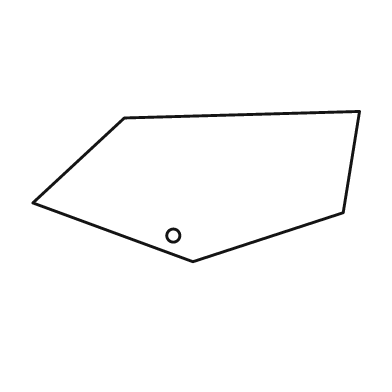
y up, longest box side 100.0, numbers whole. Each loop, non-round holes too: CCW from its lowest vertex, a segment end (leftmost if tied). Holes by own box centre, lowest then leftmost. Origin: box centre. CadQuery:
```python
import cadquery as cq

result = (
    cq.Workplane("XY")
    .moveTo(-1.0, -23.0)
    .lineTo(45.0, -8.0)
    .lineTo(50.0, 23.0)
    .lineTo(-22.0, 21.0)
    .lineTo(-50.0, -5.0)
    .close()
    .moveTo(-7.0, -15.0)
    .circle(2.0)
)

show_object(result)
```